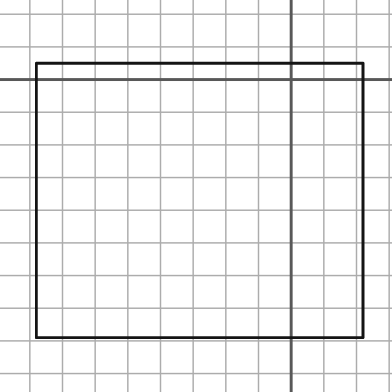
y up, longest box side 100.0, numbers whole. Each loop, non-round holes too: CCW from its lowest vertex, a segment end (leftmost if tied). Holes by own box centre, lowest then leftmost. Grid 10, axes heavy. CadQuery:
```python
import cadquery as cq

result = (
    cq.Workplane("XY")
    .moveTo(-78.0, -79.0)
    .lineTo(22.0, -79.0)
    .lineTo(22.0, 5.0)
    .lineTo(-78.0, 5.0)
    .close()
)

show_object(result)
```